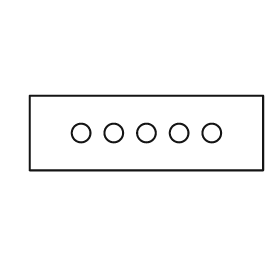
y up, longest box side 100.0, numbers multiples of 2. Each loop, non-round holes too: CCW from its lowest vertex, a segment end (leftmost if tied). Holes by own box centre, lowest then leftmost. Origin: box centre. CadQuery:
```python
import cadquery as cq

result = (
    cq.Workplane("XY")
    .moveTo(-50.0, -16.0)
    .lineTo(50.0, -16.0)
    .lineTo(50.0, 16.0)
    .lineTo(-50.0, 16.0)
    .close()
    .moveTo(-28.0, 0.0)
    .circle(4.0)
    .moveTo(-14.0, 0.0)
    .circle(4.0)
    .moveTo(0.0, 0.0)
    .circle(4.0)
    .moveTo(14.0, 0.0)
    .circle(4.0)
    .moveTo(28.0, 0.0)
    .circle(4.0)
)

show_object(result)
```